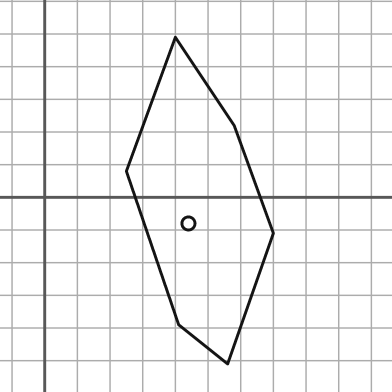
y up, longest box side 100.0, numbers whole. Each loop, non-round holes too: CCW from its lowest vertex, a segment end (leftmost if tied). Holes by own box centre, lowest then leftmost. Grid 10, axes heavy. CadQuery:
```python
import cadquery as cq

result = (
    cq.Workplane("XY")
    .moveTo(56.0, -51.0)
    .lineTo(70.0, -11.0)
    .lineTo(58.0, 22.0)
    .lineTo(40.0, 49.0)
    .lineTo(25.0, 8.0)
    .lineTo(41.0, -39.0)
    .close()
    .moveTo(44.0, -8.0)
    .circle(2.0)
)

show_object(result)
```